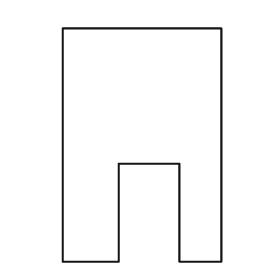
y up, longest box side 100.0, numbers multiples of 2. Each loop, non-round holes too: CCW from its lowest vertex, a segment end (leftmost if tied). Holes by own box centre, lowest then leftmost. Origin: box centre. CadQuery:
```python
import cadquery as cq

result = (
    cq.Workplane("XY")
    .moveTo(-34.0, -50.0)
    .lineTo(-10.0, -50.0)
    .lineTo(-10.0, -8.0)
    .lineTo(16.0, -8.0)
    .lineTo(16.0, -50.0)
    .lineTo(34.0, -50.0)
    .lineTo(34.0, 50.0)
    .lineTo(-34.0, 50.0)
    .close()
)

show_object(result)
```